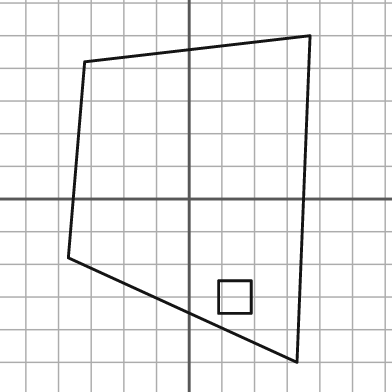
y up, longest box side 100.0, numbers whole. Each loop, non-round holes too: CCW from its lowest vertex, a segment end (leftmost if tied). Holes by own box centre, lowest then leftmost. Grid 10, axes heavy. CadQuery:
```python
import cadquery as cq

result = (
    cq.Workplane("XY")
    .moveTo(33.0, -50.0)
    .lineTo(37.0, 50.0)
    .lineTo(-32.0, 42.0)
    .lineTo(-37.0, -18.0)
    .close()
    .moveTo(9.0, -35.0)
    .lineTo(19.0, -35.0)
    .lineTo(19.0, -25.0)
    .lineTo(9.0, -25.0)
    .close()
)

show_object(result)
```